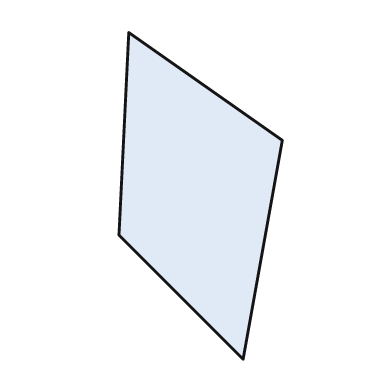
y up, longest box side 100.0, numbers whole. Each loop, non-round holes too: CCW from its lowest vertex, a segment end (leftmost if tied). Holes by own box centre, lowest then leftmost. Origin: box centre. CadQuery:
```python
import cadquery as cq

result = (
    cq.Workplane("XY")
    .moveTo(13.0, -50.0)
    .lineTo(25.0, 17.0)
    .lineTo(-22.0, 50.0)
    .lineTo(-25.0, -12.0)
    .close()
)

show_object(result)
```